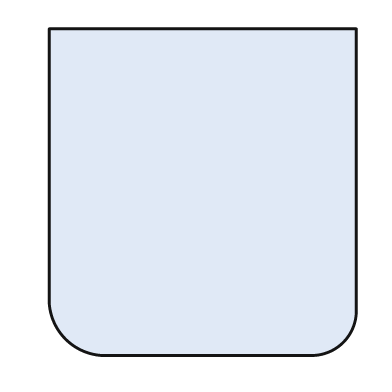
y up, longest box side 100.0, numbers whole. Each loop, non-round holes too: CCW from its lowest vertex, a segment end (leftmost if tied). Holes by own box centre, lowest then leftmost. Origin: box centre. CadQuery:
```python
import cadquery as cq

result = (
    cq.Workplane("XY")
    .moveTo(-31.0, -50.0)
    .lineTo(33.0, -50.0)
    .threePointArc((43.0, -46.0), (47.0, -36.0))
    .lineTo(47.0, 50.0)
    .lineTo(-47.0, 50.0)
    .lineTo(-47.0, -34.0)
    .threePointArc((-42.0, -45.0), (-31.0, -50.0))
    .close()
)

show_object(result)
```